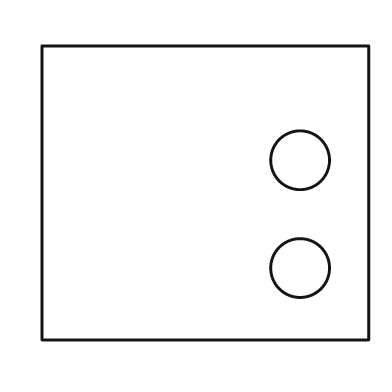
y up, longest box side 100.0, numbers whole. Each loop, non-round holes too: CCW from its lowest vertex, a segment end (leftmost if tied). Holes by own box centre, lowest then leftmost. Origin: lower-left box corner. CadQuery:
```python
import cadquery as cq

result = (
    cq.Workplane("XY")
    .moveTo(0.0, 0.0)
    .lineTo(100.0, 0.0)
    .lineTo(100.0, 90.0)
    .lineTo(0.0, 90.0)
    .close()
    .moveTo(79.0, 22.0)
    .circle(9.0)
    .moveTo(79.0, 55.0)
    .circle(9.0)
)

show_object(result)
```